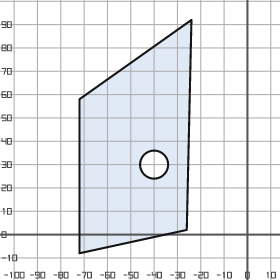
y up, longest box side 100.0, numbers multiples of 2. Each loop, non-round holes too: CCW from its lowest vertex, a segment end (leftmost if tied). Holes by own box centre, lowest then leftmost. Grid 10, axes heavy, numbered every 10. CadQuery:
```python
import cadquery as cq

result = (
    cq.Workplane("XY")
    .moveTo(-72.0, -8.0)
    .lineTo(-26.0, 2.0)
    .lineTo(-24.0, 92.0)
    .lineTo(-72.0, 58.0)
    .close()
    .moveTo(-40.0, 30.0)
    .circle(6.0)
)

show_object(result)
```